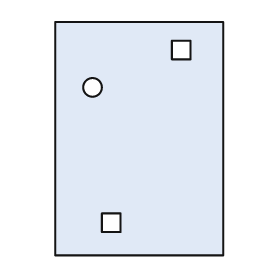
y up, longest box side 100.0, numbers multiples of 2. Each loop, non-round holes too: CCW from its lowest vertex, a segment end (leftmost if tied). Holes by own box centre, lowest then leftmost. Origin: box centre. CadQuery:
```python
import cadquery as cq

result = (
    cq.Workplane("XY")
    .moveTo(-36.0, -50.0)
    .lineTo(36.0, -50.0)
    .lineTo(36.0, 50.0)
    .lineTo(-36.0, 50.0)
    .close()
    .moveTo(-16.0, -40.0)
    .lineTo(-8.0, -40.0)
    .lineTo(-8.0, -32.0)
    .lineTo(-16.0, -32.0)
    .close()
    .moveTo(-20.0, 22.0)
    .circle(4.0)
    .moveTo(14.0, 34.0)
    .lineTo(22.0, 34.0)
    .lineTo(22.0, 42.0)
    .lineTo(14.0, 42.0)
    .close()
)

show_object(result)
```